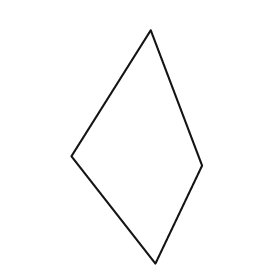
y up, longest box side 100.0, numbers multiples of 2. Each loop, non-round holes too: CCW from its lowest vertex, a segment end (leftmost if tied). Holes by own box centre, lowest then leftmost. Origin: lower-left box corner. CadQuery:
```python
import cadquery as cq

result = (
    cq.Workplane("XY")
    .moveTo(36.0, 0.0)
    .lineTo(56.0, 42.0)
    .lineTo(34.0, 100.0)
    .lineTo(0.0, 46.0)
    .close()
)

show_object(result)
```